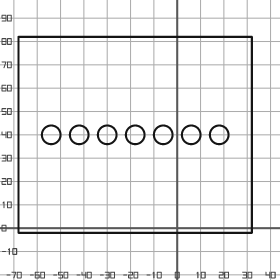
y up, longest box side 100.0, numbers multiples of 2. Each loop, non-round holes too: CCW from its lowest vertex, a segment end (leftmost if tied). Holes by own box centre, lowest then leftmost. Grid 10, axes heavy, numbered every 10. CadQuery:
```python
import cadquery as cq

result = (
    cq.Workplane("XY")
    .moveTo(-68.0, -2.0)
    .lineTo(32.0, -2.0)
    .lineTo(32.0, 82.0)
    .lineTo(-68.0, 82.0)
    .close()
    .moveTo(-54.0, 40.0)
    .circle(4.0)
    .moveTo(-42.0, 40.0)
    .circle(4.0)
    .moveTo(-30.0, 40.0)
    .circle(4.0)
    .moveTo(-18.0, 40.0)
    .circle(4.0)
    .moveTo(-6.0, 40.0)
    .circle(4.0)
    .moveTo(6.0, 40.0)
    .circle(4.0)
    .moveTo(18.0, 40.0)
    .circle(4.0)
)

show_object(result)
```